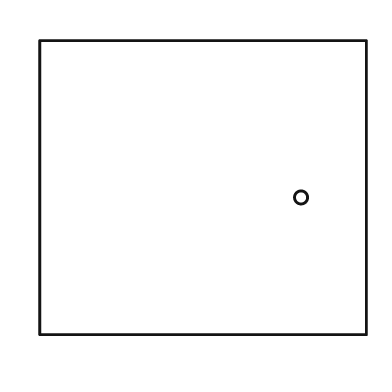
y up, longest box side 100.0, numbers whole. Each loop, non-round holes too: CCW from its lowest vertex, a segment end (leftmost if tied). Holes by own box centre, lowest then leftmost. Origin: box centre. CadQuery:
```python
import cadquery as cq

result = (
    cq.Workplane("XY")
    .moveTo(-50.0, -45.0)
    .lineTo(50.0, -45.0)
    .lineTo(50.0, 45.0)
    .lineTo(-50.0, 45.0)
    .close()
    .moveTo(30.0, -3.0)
    .circle(2.0)
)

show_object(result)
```